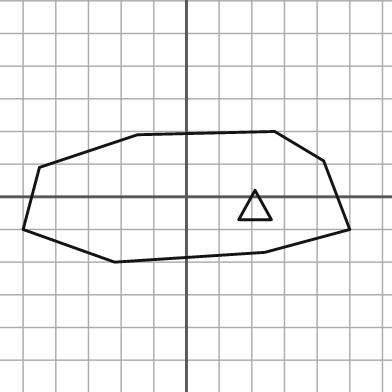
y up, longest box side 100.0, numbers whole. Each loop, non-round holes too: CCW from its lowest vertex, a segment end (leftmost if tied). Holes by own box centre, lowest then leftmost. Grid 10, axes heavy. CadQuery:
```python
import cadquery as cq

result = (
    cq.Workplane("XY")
    .moveTo(-22.0, -20.0)
    .lineTo(24.0, -17.0)
    .lineTo(50.0, -10.0)
    .lineTo(42.0, 11.0)
    .lineTo(27.0, 20.0)
    .lineTo(-15.0, 19.0)
    .lineTo(-45.0, 9.0)
    .lineTo(-50.0, -10.0)
    .close()
    .moveTo(16.0, -7.0)
    .lineTo(26.0, -7.0)
    .lineTo(21.0, 2.0)
    .close()
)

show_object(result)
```